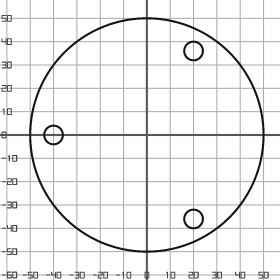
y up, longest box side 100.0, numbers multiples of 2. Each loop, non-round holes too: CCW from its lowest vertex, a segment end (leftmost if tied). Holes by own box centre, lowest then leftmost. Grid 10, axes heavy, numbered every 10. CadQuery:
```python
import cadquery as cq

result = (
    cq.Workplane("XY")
    .moveTo(0.0, 0.0)
    .circle(50.0)
    .moveTo(20.0, -36.0)
    .circle(4.0)
    .moveTo(-40.0, 0.0)
    .circle(4.0)
    .moveTo(20.0, 36.0)
    .circle(4.0)
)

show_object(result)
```